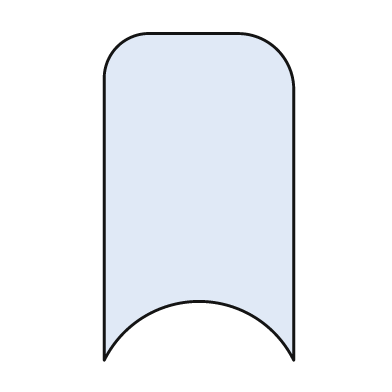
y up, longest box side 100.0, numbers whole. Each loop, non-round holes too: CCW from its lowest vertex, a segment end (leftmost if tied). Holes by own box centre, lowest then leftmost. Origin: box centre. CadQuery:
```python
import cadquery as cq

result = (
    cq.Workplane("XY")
    .moveTo(-29.0, -50.0)
    .threePointArc((0.0, -32.0), (29.0, -50.0))
    .lineTo(29.0, 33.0)
    .threePointArc((24.0, 45.0), (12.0, 50.0))
    .lineTo(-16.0, 50.0)
    .threePointArc((-25.0, 46.0), (-29.0, 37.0))
    .close()
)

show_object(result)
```